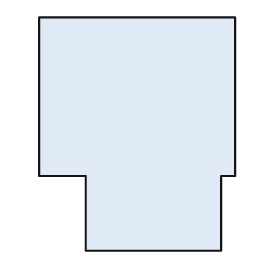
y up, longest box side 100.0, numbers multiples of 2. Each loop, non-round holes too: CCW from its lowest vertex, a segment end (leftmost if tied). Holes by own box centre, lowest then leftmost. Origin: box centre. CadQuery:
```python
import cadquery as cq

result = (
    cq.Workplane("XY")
    .moveTo(-22.0, -50.0)
    .lineTo(36.0, -50.0)
    .lineTo(36.0, -18.0)
    .lineTo(42.0, -18.0)
    .lineTo(42.0, 50.0)
    .lineTo(-42.0, 50.0)
    .lineTo(-42.0, -18.0)
    .lineTo(-22.0, -18.0)
    .close()
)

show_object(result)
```